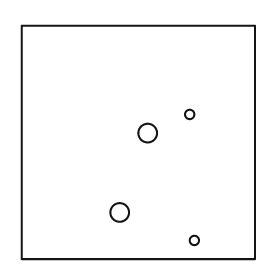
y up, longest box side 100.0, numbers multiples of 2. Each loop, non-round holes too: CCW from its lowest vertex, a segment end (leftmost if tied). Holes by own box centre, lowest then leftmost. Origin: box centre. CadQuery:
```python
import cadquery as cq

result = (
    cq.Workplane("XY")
    .moveTo(-50.0, -50.0)
    .lineTo(50.0, -50.0)
    .lineTo(50.0, 50.0)
    .lineTo(-50.0, 50.0)
    .close()
    .moveTo(24.0, -42.0)
    .circle(2.0)
    .moveTo(-8.0, -30.0)
    .circle(4.0)
    .moveTo(4.0, 4.0)
    .circle(4.0)
    .moveTo(22.0, 12.0)
    .circle(2.0)
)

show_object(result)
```